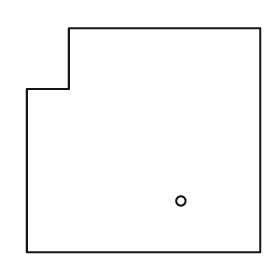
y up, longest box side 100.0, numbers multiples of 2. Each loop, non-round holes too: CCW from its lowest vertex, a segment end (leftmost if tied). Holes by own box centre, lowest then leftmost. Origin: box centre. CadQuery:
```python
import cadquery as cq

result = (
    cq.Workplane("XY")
    .moveTo(-50.0, -48.0)
    .lineTo(50.0, -48.0)
    .lineTo(50.0, 48.0)
    .lineTo(-32.0, 48.0)
    .lineTo(-32.0, 22.0)
    .lineTo(-50.0, 22.0)
    .close()
    .moveTo(16.0, -26.0)
    .circle(2.0)
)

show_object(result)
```